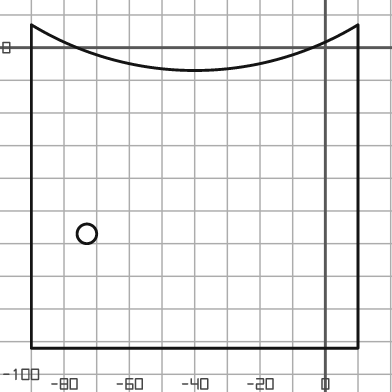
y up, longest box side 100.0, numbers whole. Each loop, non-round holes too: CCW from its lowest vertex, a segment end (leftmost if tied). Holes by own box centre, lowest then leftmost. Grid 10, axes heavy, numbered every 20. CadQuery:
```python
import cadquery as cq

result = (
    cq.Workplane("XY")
    .moveTo(-90.0, -92.0)
    .lineTo(10.0, -92.0)
    .lineTo(10.0, 7.0)
    .threePointArc((-40.0, -7.0), (-90.0, 7.0))
    .close()
    .moveTo(-73.0, -57.0)
    .circle(3.0)
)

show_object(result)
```